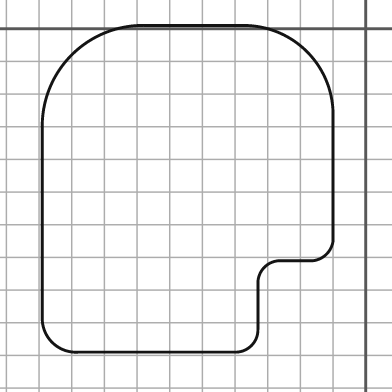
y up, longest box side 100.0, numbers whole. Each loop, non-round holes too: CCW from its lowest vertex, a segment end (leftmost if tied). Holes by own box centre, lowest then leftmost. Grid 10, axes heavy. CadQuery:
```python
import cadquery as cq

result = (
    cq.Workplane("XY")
    .moveTo(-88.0, -99.0)
    .lineTo(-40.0, -99.0)
    .threePointArc((-35.0, -97.0), (-33.0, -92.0))
    .lineTo(-33.0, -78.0)
    .threePointArc((-31.0, -73.0), (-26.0, -71.0))
    .lineTo(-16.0, -71.0)
    .threePointArc((-12.0, -69.0), (-10.0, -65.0))
    .lineTo(-10.0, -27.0)
    .threePointArc((-18.0, -7.0), (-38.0, 1.0))
    .lineTo(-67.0, 1.0)
    .threePointArc((-90.0, -8.0), (-99.0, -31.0))
    .lineTo(-99.0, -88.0)
    .threePointArc((-96.0, -96.0), (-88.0, -99.0))
    .close()
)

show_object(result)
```